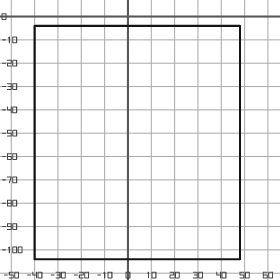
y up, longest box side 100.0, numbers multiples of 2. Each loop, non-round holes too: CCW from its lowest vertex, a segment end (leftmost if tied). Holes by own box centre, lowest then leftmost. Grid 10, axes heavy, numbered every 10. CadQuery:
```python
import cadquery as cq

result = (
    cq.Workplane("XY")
    .moveTo(-40.0, -104.0)
    .lineTo(48.0, -104.0)
    .lineTo(48.0, -4.0)
    .lineTo(-40.0, -4.0)
    .close()
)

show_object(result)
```